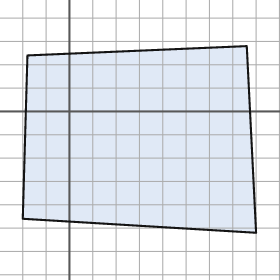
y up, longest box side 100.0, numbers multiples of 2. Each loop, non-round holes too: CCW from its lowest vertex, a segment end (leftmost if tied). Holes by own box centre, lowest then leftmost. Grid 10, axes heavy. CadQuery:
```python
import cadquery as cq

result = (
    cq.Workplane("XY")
    .moveTo(80.0, -52.0)
    .lineTo(76.0, 28.0)
    .lineTo(-18.0, 24.0)
    .lineTo(-20.0, -46.0)
    .close()
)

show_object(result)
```